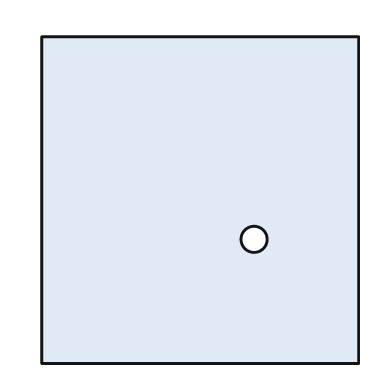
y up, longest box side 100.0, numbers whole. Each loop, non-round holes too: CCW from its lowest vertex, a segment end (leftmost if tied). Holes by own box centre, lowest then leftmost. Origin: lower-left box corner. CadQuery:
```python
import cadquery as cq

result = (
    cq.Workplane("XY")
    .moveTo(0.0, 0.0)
    .lineTo(97.0, 0.0)
    .lineTo(97.0, 100.0)
    .lineTo(0.0, 100.0)
    .close()
    .moveTo(65.0, 38.0)
    .circle(4.0)
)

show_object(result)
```